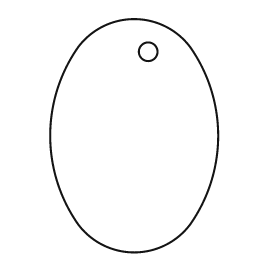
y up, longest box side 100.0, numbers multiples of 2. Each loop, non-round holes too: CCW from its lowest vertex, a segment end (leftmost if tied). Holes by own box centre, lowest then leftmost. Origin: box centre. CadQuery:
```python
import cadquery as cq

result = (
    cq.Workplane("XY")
    .moveTo(-24.0, -38.0)
    .threePointArc((0.0, -50.0), (24.0, -38.0))
    .threePointArc((36.0, 0.0), (24.0, 38.0))
    .threePointArc((0.0, 50.0), (-24.0, 38.0))
    .threePointArc((-36.0, 0.0), (-24.0, -38.0))
    .close()
    .moveTo(6.0, 36.0)
    .circle(4.0)
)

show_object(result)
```